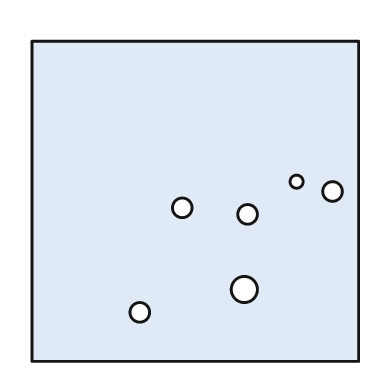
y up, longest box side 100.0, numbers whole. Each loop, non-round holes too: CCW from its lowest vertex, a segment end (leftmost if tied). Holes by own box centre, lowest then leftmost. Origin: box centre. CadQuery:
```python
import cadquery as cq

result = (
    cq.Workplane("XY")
    .moveTo(-50.0, -49.0)
    .lineTo(50.0, -49.0)
    .lineTo(50.0, 49.0)
    .lineTo(-50.0, 49.0)
    .close()
    .moveTo(-17.0, -34.0)
    .circle(3.0)
    .moveTo(15.0, -27.0)
    .circle(4.0)
    .moveTo(16.0, -4.0)
    .circle(3.0)
    .moveTo(-4.0, -2.0)
    .circle(3.0)
    .moveTo(42.0, 3.0)
    .circle(3.0)
    .moveTo(31.0, 6.0)
    .circle(2.0)
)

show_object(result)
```